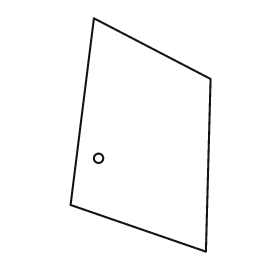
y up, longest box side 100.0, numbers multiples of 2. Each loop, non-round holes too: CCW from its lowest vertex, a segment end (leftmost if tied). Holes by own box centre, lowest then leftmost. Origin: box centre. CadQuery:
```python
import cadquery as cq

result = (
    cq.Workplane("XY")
    .moveTo(28.0, -50.0)
    .lineTo(30.0, 24.0)
    .lineTo(-20.0, 50.0)
    .lineTo(-30.0, -30.0)
    .close()
    .moveTo(-18.0, -10.0)
    .circle(2.0)
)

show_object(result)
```